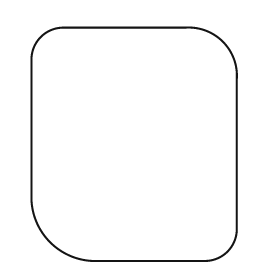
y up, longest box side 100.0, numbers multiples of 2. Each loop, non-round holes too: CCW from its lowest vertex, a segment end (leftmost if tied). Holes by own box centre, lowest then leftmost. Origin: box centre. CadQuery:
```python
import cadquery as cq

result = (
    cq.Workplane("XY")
    .moveTo(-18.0, -50.0)
    .lineTo(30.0, -50.0)
    .threePointArc((40.0, -46.0), (44.0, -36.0))
    .lineTo(44.0, 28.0)
    .threePointArc((38.0, 44.0), (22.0, 50.0))
    .lineTo(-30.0, 50.0)
    .threePointArc((-40.0, 46.0), (-44.0, 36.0))
    .lineTo(-44.0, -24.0)
    .threePointArc((-36.0, -42.0), (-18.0, -50.0))
    .close()
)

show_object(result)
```